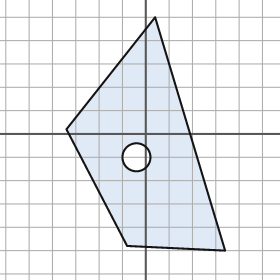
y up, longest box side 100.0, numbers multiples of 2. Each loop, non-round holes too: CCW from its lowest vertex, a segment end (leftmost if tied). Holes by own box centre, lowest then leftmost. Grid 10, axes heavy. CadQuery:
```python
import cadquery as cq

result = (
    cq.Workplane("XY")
    .moveTo(34.0, -50.0)
    .lineTo(4.0, 50.0)
    .lineTo(-34.0, 2.0)
    .lineTo(-8.0, -48.0)
    .close()
    .moveTo(-4.0, -10.0)
    .circle(6.0)
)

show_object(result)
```